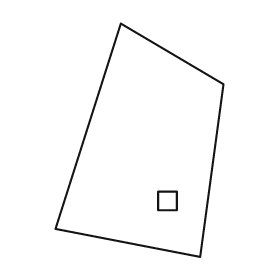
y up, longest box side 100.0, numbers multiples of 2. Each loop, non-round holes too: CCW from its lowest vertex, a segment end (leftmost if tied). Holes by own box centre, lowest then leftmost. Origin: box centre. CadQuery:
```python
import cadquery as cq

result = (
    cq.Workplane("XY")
    .moveTo(26.0, -50.0)
    .lineTo(36.0, 24.0)
    .lineTo(-8.0, 50.0)
    .lineTo(-36.0, -38.0)
    .close()
    .moveTo(8.0, -30.0)
    .lineTo(16.0, -30.0)
    .lineTo(16.0, -22.0)
    .lineTo(8.0, -22.0)
    .close()
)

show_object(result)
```